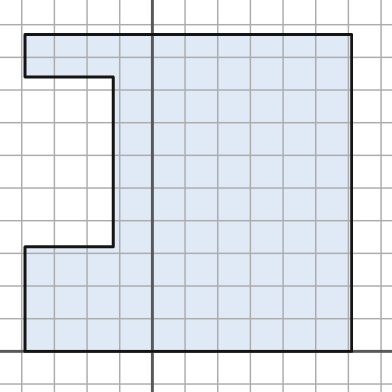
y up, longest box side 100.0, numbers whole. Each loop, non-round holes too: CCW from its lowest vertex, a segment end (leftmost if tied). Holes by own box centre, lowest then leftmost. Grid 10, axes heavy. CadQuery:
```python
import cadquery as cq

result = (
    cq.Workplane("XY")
    .moveTo(-39.0, 0.0)
    .lineTo(61.0, 0.0)
    .lineTo(61.0, 97.0)
    .lineTo(-39.0, 97.0)
    .lineTo(-39.0, 84.0)
    .lineTo(-12.0, 84.0)
    .lineTo(-12.0, 32.0)
    .lineTo(-39.0, 32.0)
    .close()
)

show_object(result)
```